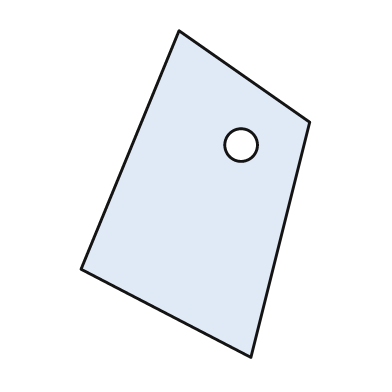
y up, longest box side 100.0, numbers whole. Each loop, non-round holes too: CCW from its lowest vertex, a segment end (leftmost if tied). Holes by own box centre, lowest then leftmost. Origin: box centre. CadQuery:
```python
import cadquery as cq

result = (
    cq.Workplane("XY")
    .moveTo(17.0, -50.0)
    .lineTo(35.0, 22.0)
    .lineTo(-5.0, 50.0)
    .lineTo(-35.0, -23.0)
    .close()
    .moveTo(14.0, 15.0)
    .circle(5.0)
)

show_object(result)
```